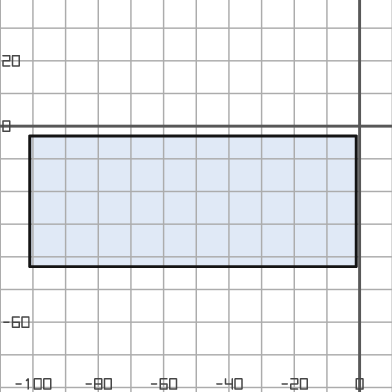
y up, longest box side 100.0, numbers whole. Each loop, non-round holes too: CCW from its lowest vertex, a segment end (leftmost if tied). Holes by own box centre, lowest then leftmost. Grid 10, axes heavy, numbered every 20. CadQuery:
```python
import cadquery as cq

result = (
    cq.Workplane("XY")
    .moveTo(-101.0, -43.0)
    .lineTo(-1.0, -43.0)
    .lineTo(-1.0, -3.0)
    .lineTo(-101.0, -3.0)
    .close()
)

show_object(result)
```